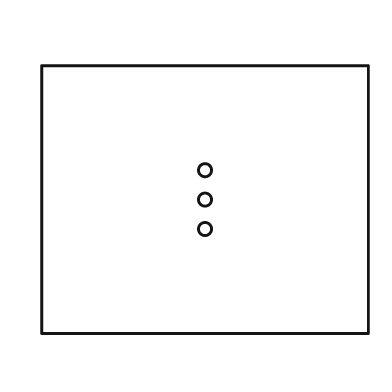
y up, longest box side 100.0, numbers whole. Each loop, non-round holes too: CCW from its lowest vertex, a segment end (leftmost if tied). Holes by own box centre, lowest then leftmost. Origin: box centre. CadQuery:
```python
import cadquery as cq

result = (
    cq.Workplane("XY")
    .moveTo(-50.0, -41.0)
    .lineTo(50.0, -41.0)
    .lineTo(50.0, 41.0)
    .lineTo(-50.0, 41.0)
    .close()
    .moveTo(0.0, -9.0)
    .circle(2.0)
    .moveTo(0.0, 0.0)
    .circle(2.0)
    .moveTo(0.0, 9.0)
    .circle(2.0)
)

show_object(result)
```